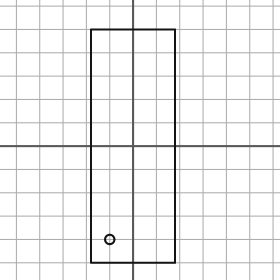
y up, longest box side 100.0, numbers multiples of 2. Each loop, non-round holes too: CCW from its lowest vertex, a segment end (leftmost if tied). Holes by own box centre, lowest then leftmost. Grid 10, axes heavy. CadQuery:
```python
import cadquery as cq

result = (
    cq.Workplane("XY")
    .moveTo(-18.0, -50.0)
    .lineTo(18.0, -50.0)
    .lineTo(18.0, 50.0)
    .lineTo(-18.0, 50.0)
    .close()
    .moveTo(-10.0, -40.0)
    .circle(2.0)
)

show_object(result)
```